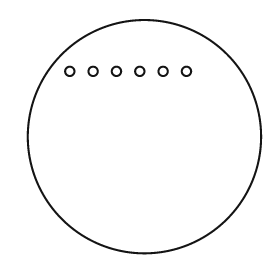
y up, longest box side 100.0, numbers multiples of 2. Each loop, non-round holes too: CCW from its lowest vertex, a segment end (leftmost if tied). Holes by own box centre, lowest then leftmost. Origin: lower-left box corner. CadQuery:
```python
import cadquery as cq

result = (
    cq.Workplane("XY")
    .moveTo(50.0, 50.0)
    .circle(50.0)
    .moveTo(18.0, 78.0)
    .circle(2.0)
    .moveTo(28.0, 78.0)
    .circle(2.0)
    .moveTo(38.0, 78.0)
    .circle(2.0)
    .moveTo(48.0, 78.0)
    .circle(2.0)
    .moveTo(58.0, 78.0)
    .circle(2.0)
    .moveTo(68.0, 78.0)
    .circle(2.0)
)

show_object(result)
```